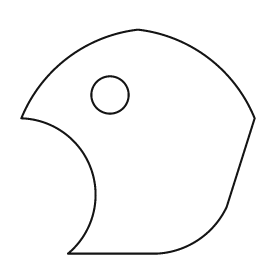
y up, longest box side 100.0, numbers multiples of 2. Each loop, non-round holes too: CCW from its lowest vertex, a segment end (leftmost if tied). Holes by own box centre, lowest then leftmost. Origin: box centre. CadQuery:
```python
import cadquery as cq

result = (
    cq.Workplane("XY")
    .moveTo(-30.0, -48.0)
    .lineTo(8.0, -48.0)
    .threePointArc((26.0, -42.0), (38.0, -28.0))
    .lineTo(50.0, 10.0)
    .threePointArc((30.0, 36.0), (0.0, 48.0))
    .threePointArc((-30.0, 36.0), (-50.0, 10.0))
    .threePointArc((-20.0, -12.0), (-30.0, -48.0))
    .close()
    .moveTo(-12.0, 20.0)
    .circle(8.0)
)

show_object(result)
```